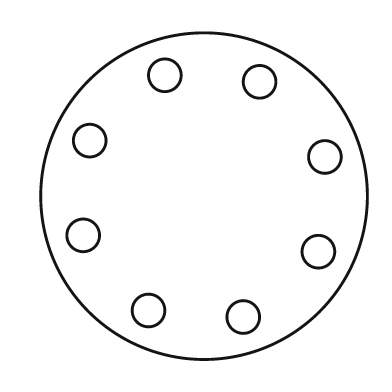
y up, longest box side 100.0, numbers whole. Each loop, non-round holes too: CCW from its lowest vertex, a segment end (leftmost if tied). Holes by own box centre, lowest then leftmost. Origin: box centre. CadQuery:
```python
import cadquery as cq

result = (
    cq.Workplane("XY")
    .moveTo(0.0, 0.0)
    .circle(50.0)
    .moveTo(12.0, -37.0)
    .circle(5.0)
    .moveTo(-17.0, -35.0)
    .circle(5.0)
    .moveTo(35.0, -17.0)
    .circle(5.0)
    .moveTo(-37.0, -12.0)
    .circle(5.0)
    .moveTo(37.0, 12.0)
    .circle(5.0)
    .moveTo(-35.0, 17.0)
    .circle(5.0)
    .moveTo(17.0, 35.0)
    .circle(5.0)
    .moveTo(-12.0, 37.0)
    .circle(5.0)
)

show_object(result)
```